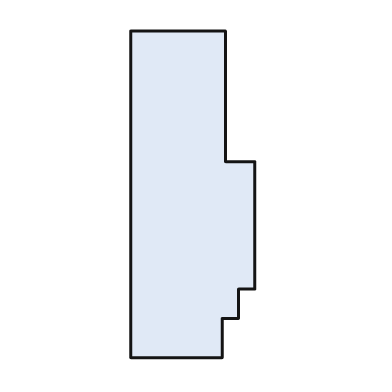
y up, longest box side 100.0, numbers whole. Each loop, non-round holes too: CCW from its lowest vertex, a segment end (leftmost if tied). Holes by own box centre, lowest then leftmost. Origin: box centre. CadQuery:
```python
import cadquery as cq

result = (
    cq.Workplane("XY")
    .moveTo(-19.0, -50.0)
    .lineTo(9.0, -50.0)
    .lineTo(9.0, -38.0)
    .lineTo(14.0, -38.0)
    .lineTo(14.0, -29.0)
    .lineTo(19.0, -29.0)
    .lineTo(19.0, 10.0)
    .lineTo(10.0, 10.0)
    .lineTo(10.0, 50.0)
    .lineTo(-19.0, 50.0)
    .close()
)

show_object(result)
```